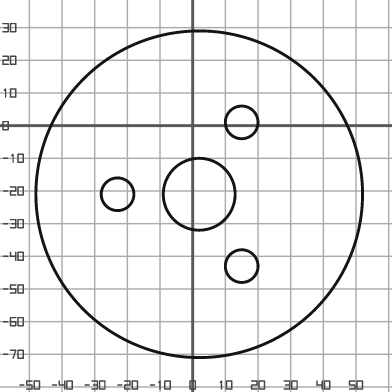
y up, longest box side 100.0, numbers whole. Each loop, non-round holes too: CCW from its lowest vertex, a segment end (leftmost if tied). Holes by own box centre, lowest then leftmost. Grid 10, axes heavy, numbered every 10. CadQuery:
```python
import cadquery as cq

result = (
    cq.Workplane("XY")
    .moveTo(2.0, -21.0)
    .circle(50.0)
    .moveTo(15.0, -43.0)
    .circle(5.0)
    .moveTo(-23.0, -21.0)
    .circle(5.0)
    .moveTo(2.0, -21.0)
    .circle(11.0)
    .moveTo(15.0, 1.0)
    .circle(5.0)
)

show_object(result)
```